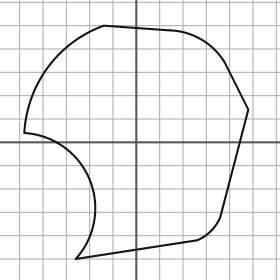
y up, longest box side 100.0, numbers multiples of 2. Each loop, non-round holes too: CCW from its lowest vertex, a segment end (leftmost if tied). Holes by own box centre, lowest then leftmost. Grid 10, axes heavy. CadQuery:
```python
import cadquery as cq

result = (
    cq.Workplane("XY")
    .moveTo(-26.0, -50.0)
    .lineTo(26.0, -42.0)
    .threePointArc((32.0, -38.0), (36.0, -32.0))
    .lineTo(48.0, 14.0)
    .lineTo(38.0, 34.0)
    .threePointArc((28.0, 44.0), (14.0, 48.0))
    .lineTo(-14.0, 50.0)
    .threePointArc((-38.0, 32.0), (-48.0, 4.0))
    .threePointArc((-20.0, -16.0), (-26.0, -50.0))
    .close()
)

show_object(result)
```